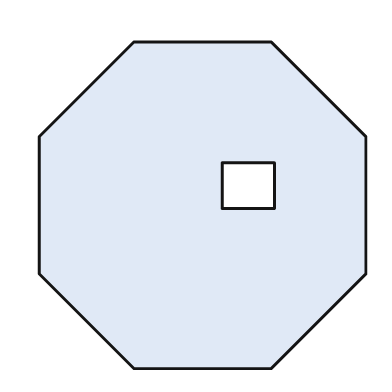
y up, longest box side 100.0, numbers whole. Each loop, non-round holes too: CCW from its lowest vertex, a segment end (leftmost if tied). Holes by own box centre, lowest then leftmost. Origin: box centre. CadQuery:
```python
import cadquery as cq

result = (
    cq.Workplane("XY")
    .moveTo(-21.0, -50.0)
    .lineTo(21.0, -50.0)
    .lineTo(50.0, -21.0)
    .lineTo(50.0, 21.0)
    .lineTo(21.0, 50.0)
    .lineTo(-21.0, 50.0)
    .lineTo(-50.0, 21.0)
    .lineTo(-50.0, -21.0)
    .close()
    .moveTo(6.0, -1.0)
    .lineTo(22.0, -1.0)
    .lineTo(22.0, 13.0)
    .lineTo(6.0, 13.0)
    .close()
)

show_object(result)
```